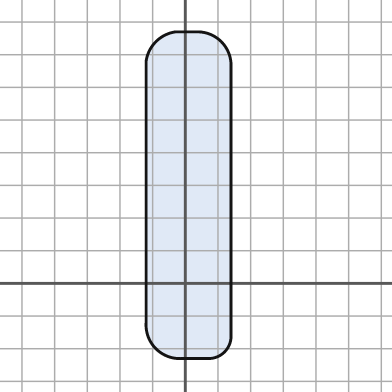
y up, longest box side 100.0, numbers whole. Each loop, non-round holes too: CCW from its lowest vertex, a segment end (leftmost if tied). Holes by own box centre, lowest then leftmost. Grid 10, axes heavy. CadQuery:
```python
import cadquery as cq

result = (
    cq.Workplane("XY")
    .moveTo(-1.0, -23.0)
    .lineTo(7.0, -23.0)
    .threePointArc((12.0, -21.0), (14.0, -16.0))
    .lineTo(14.0, 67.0)
    .threePointArc((11.0, 74.0), (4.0, 77.0))
    .lineTo(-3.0, 77.0)
    .threePointArc((-9.0, 74.0), (-12.0, 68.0))
    .lineTo(-12.0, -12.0)
    .threePointArc((-9.0, -20.0), (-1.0, -23.0))
    .close()
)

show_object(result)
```